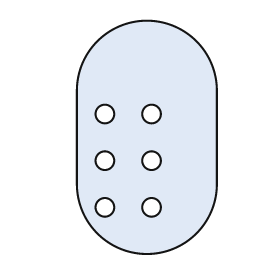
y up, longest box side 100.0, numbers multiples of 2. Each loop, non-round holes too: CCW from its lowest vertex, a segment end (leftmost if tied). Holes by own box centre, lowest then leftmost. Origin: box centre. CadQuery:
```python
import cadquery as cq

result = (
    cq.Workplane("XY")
    .moveTo(-30.0, -20.0)
    .threePointArc((0.0, -50.0), (30.0, -20.0))
    .lineTo(30.0, 20.0)
    .threePointArc((0.0, 50.0), (-30.0, 20.0))
    .close()
    .moveTo(-18.0, -30.0)
    .circle(4.0)
    .moveTo(2.0, -30.0)
    .circle(4.0)
    .moveTo(-18.0, -10.0)
    .circle(4.0)
    .moveTo(2.0, -10.0)
    .circle(4.0)
    .moveTo(-18.0, 10.0)
    .circle(4.0)
    .moveTo(2.0, 10.0)
    .circle(4.0)
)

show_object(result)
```